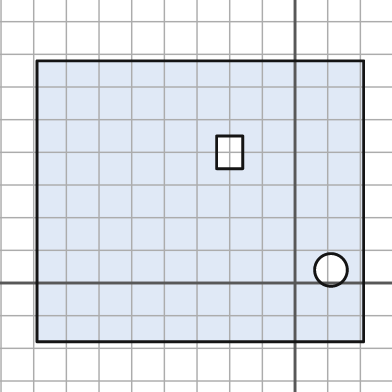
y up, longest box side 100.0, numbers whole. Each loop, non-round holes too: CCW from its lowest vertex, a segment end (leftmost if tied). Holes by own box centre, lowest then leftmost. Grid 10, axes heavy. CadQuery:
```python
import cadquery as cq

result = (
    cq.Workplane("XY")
    .moveTo(-79.0, -18.0)
    .lineTo(21.0, -18.0)
    .lineTo(21.0, 68.0)
    .lineTo(-79.0, 68.0)
    .close()
    .moveTo(11.0, 4.0)
    .circle(5.0)
    .moveTo(-24.0, 35.0)
    .lineTo(-16.0, 35.0)
    .lineTo(-16.0, 45.0)
    .lineTo(-24.0, 45.0)
    .close()
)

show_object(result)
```